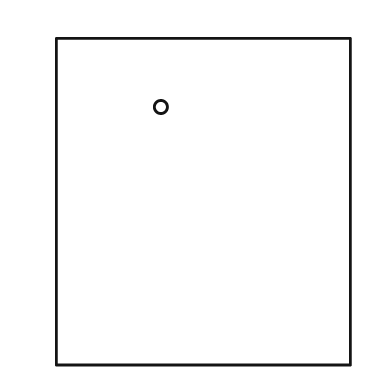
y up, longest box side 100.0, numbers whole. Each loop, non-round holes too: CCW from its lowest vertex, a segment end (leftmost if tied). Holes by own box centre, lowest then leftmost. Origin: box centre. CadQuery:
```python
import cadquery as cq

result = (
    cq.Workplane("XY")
    .moveTo(-45.0, -50.0)
    .lineTo(45.0, -50.0)
    .lineTo(45.0, 50.0)
    .lineTo(-45.0, 50.0)
    .close()
    .moveTo(-13.0, 29.0)
    .circle(2.0)
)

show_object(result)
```